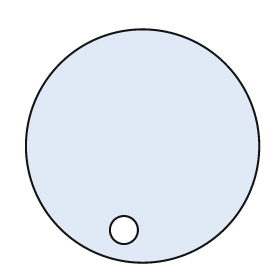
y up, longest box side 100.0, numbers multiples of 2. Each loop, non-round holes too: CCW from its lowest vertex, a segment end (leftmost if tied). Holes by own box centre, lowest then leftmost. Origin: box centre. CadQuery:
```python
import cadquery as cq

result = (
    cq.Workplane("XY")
    .moveTo(0.0, 0.0)
    .circle(50.0)
    .moveTo(-8.0, -36.0)
    .circle(6.0)
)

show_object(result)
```